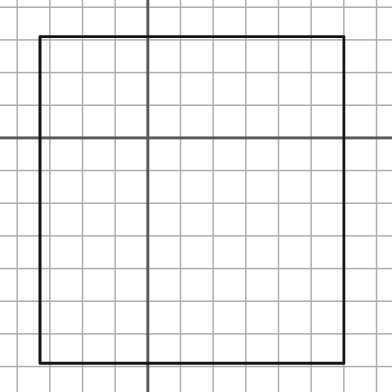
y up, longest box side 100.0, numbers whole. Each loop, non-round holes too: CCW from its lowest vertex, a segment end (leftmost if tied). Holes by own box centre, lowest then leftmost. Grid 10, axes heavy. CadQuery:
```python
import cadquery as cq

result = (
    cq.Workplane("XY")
    .moveTo(-33.0, -69.0)
    .lineTo(60.0, -69.0)
    .lineTo(60.0, 31.0)
    .lineTo(-33.0, 31.0)
    .close()
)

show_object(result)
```